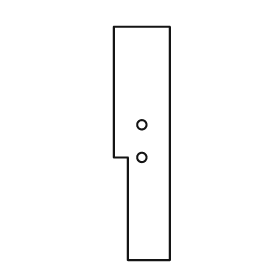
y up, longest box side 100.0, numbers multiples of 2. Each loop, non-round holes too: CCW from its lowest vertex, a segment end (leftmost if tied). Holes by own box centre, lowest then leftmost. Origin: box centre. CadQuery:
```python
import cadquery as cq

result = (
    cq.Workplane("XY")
    .moveTo(-6.0, -50.0)
    .lineTo(12.0, -50.0)
    .lineTo(12.0, 50.0)
    .lineTo(-12.0, 50.0)
    .lineTo(-12.0, -6.0)
    .lineTo(-6.0, -6.0)
    .close()
    .moveTo(0.0, -6.0)
    .circle(2.0)
    .moveTo(0.0, 8.0)
    .circle(2.0)
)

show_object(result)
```